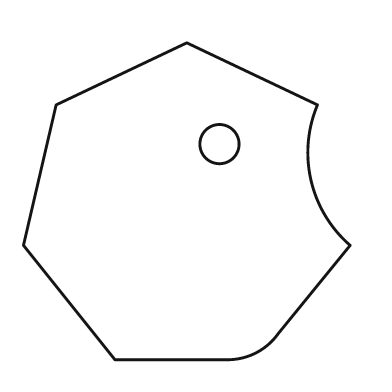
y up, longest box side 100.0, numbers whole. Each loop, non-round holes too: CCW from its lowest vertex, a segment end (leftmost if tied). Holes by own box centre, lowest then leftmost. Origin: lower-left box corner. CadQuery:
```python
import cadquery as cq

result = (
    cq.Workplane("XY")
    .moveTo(28.0, 0.0)
    .lineTo(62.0, 0.0)
    .threePointArc((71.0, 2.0), (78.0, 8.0))
    .lineTo(100.0, 35.0)
    .threePointArc((88.0, 55.0), (90.0, 78.0))
    .lineTo(50.0, 97.0)
    .lineTo(10.0, 78.0)
    .lineTo(0.0, 35.0)
    .close()
    .moveTo(60.0, 66.0)
    .circle(6.0)
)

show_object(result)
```